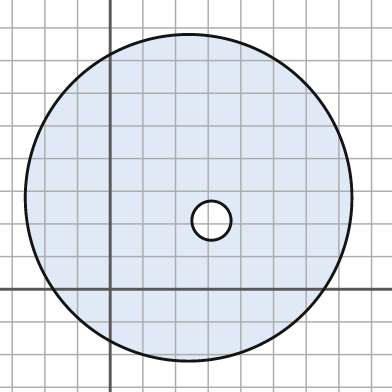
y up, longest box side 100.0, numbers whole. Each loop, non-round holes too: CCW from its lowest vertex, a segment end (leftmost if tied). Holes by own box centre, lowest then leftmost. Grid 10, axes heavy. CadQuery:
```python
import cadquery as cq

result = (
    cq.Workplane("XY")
    .moveTo(24.0, 28.0)
    .circle(50.0)
    .moveTo(31.0, 21.0)
    .circle(6.0)
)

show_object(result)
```